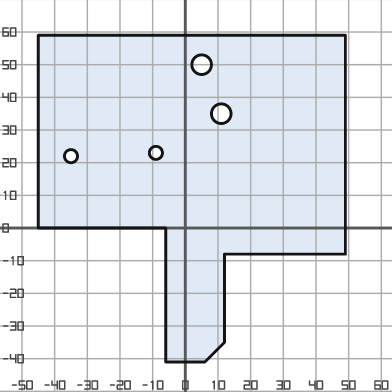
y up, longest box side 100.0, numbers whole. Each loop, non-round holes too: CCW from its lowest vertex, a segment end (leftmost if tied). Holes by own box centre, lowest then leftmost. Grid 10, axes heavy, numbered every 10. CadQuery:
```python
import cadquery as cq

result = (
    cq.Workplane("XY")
    .moveTo(-6.0, -41.0)
    .lineTo(6.0, -41.0)
    .lineTo(12.0, -35.0)
    .lineTo(12.0, -8.0)
    .lineTo(49.0, -8.0)
    .lineTo(49.0, 59.0)
    .lineTo(-45.0, 59.0)
    .lineTo(-45.0, 0.0)
    .lineTo(-6.0, 0.0)
    .close()
    .moveTo(-35.0, 22.0)
    .circle(2.0)
    .moveTo(-9.0, 23.0)
    .circle(2.0)
    .moveTo(11.0, 35.0)
    .circle(3.0)
    .moveTo(5.0, 50.0)
    .circle(3.0)
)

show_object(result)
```